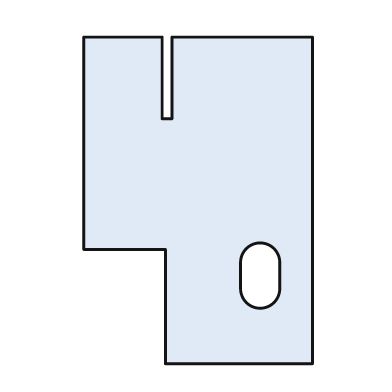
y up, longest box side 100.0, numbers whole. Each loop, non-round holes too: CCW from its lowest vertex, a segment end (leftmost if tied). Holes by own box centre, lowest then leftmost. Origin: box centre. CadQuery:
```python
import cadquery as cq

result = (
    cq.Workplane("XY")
    .moveTo(-10.0, -50.0)
    .lineTo(35.0, -50.0)
    .lineTo(35.0, 50.0)
    .lineTo(-8.0, 50.0)
    .lineTo(-8.0, 25.0)
    .lineTo(-11.0, 25.0)
    .lineTo(-11.0, 50.0)
    .lineTo(-35.0, 50.0)
    .lineTo(-35.0, -15.0)
    .lineTo(-10.0, -15.0)
    .close()
    .moveTo(13.0, -27.0)
    .threePointArc((19.0, -33.0), (25.0, -27.0))
    .lineTo(25.0, -19.0)
    .threePointArc((19.0, -13.0), (13.0, -19.0))
    .close()
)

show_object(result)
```